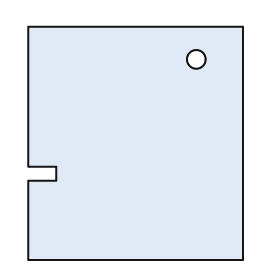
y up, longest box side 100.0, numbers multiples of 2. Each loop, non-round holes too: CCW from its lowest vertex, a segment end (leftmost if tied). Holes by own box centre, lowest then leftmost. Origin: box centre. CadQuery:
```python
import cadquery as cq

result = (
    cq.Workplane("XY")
    .moveTo(-46.0, -50.0)
    .lineTo(46.0, -50.0)
    .lineTo(46.0, 50.0)
    .lineTo(-46.0, 50.0)
    .lineTo(-46.0, -10.0)
    .lineTo(-34.0, -10.0)
    .lineTo(-34.0, -16.0)
    .lineTo(-46.0, -16.0)
    .close()
    .moveTo(26.0, 36.0)
    .circle(4.0)
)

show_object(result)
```